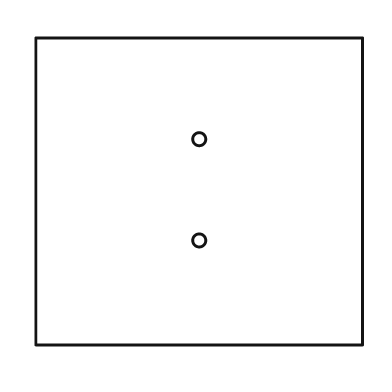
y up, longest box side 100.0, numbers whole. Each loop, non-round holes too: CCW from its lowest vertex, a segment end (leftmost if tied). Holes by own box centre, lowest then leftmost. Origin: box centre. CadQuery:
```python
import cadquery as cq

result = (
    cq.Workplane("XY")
    .moveTo(-50.0, -47.0)
    .lineTo(50.0, -47.0)
    .lineTo(50.0, 47.0)
    .lineTo(-50.0, 47.0)
    .close()
    .moveTo(0.0, -15.0)
    .circle(2.0)
    .moveTo(0.0, 16.0)
    .circle(2.0)
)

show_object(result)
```